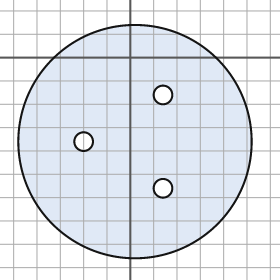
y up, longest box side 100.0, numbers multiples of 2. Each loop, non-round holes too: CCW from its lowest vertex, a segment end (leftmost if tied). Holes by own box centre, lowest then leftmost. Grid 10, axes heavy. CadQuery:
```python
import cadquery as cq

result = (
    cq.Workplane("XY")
    .moveTo(2.0, -36.0)
    .circle(50.0)
    .moveTo(14.0, -56.0)
    .circle(4.0)
    .moveTo(-20.0, -36.0)
    .circle(4.0)
    .moveTo(14.0, -16.0)
    .circle(4.0)
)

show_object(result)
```